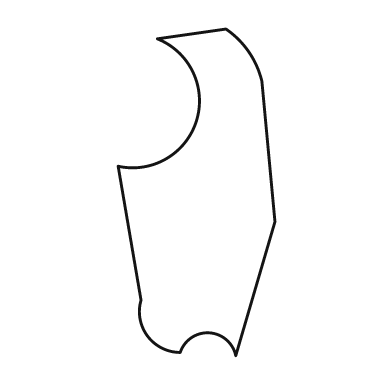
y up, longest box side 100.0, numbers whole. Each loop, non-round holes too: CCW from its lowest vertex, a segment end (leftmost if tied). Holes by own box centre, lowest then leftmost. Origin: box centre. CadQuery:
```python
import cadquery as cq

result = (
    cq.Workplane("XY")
    .moveTo(12.0, -50.0)
    .lineTo(24.0, -9.0)
    .lineTo(20.0, 34.0)
    .threePointArc((16.0, 43.0), (9.0, 50.0))
    .lineTo(-12.0, 47.0)
    .threePointArc((0.0, 22.0), (-24.0, 8.0))
    .lineTo(-17.0, -33.0)
    .threePointArc((-15.0, -44.0), (-5.0, -49.0))
    .threePointArc((4.0, -43.0), (12.0, -50.0))
    .close()
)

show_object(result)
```